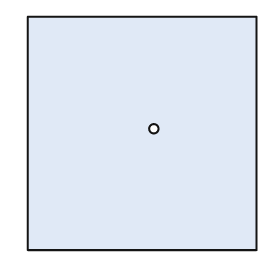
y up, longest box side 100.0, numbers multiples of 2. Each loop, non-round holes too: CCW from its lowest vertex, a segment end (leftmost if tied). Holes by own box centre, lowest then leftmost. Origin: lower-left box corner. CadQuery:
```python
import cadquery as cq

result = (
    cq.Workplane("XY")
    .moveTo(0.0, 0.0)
    .lineTo(98.0, 0.0)
    .lineTo(98.0, 100.0)
    .lineTo(0.0, 100.0)
    .close()
    .moveTo(54.0, 52.0)
    .circle(2.0)
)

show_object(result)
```